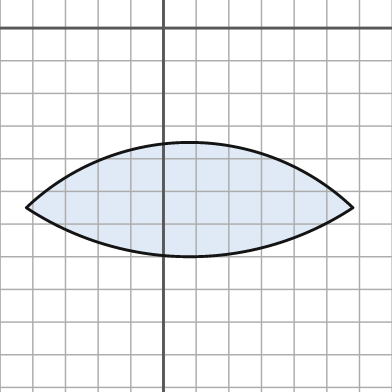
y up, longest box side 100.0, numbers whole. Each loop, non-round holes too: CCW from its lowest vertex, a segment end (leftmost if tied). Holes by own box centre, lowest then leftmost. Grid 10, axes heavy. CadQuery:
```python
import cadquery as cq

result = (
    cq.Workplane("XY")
    .moveTo(-42.0, -55.0)
    .threePointArc((8.0, -70.0), (58.0, -55.0))
    .threePointArc((8.0, -35.0), (-42.0, -55.0))
    .close()
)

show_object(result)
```